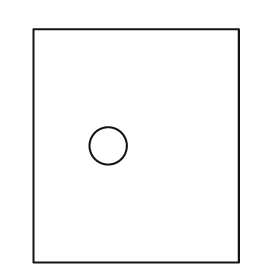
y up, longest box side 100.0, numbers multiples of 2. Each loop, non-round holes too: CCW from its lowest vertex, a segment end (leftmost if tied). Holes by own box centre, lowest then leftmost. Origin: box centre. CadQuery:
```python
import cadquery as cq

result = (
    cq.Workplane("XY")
    .moveTo(-44.0, -50.0)
    .lineTo(44.0, -50.0)
    .lineTo(44.0, 50.0)
    .lineTo(-44.0, 50.0)
    .close()
    .moveTo(-12.0, 0.0)
    .circle(8.0)
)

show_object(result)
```